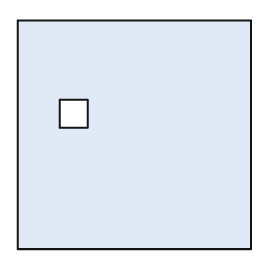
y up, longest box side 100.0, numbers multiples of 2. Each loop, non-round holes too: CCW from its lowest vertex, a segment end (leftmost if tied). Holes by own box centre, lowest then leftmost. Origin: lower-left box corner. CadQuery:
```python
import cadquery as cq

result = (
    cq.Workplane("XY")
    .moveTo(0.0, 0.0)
    .lineTo(100.0, 0.0)
    .lineTo(100.0, 98.0)
    .lineTo(0.0, 98.0)
    .close()
    .moveTo(18.0, 52.0)
    .lineTo(30.0, 52.0)
    .lineTo(30.0, 64.0)
    .lineTo(18.0, 64.0)
    .close()
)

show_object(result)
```